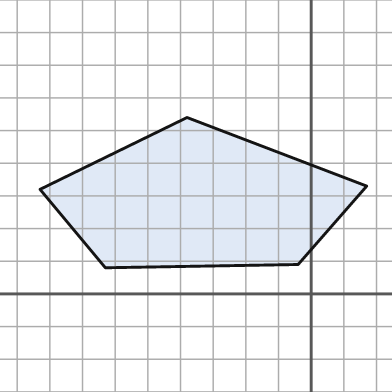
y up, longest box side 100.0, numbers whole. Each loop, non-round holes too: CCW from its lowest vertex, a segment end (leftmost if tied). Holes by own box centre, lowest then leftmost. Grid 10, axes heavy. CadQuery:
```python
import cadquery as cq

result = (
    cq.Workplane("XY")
    .moveTo(-63.0, 8.0)
    .lineTo(-4.0, 9.0)
    .lineTo(17.0, 33.0)
    .lineTo(-38.0, 54.0)
    .lineTo(-83.0, 32.0)
    .close()
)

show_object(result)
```